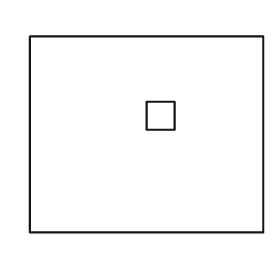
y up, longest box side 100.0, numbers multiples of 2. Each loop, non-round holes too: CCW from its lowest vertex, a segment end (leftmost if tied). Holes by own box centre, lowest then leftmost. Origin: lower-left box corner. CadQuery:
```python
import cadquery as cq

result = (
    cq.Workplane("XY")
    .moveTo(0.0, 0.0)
    .lineTo(100.0, 0.0)
    .lineTo(100.0, 84.0)
    .lineTo(0.0, 84.0)
    .close()
    .moveTo(50.0, 44.0)
    .lineTo(62.0, 44.0)
    .lineTo(62.0, 56.0)
    .lineTo(50.0, 56.0)
    .close()
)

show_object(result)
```